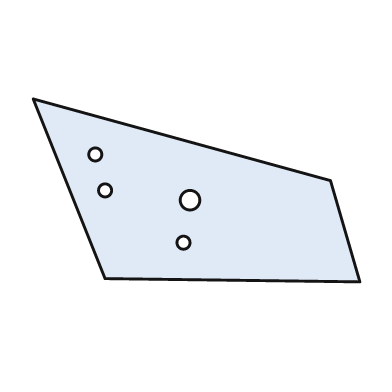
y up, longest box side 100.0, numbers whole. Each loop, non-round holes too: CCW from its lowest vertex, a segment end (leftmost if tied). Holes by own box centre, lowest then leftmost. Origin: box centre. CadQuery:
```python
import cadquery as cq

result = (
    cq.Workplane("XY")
    .moveTo(50.0, -28.0)
    .lineTo(41.0, 3.0)
    .lineTo(-50.0, 28.0)
    .lineTo(-28.0, -27.0)
    .close()
    .moveTo(-4.0, -16.0)
    .circle(2.0)
    .moveTo(-2.0, -3.0)
    .circle(3.0)
    .moveTo(-28.0, 0.0)
    .circle(2.0)
    .moveTo(-31.0, 11.0)
    .circle(2.0)
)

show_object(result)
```